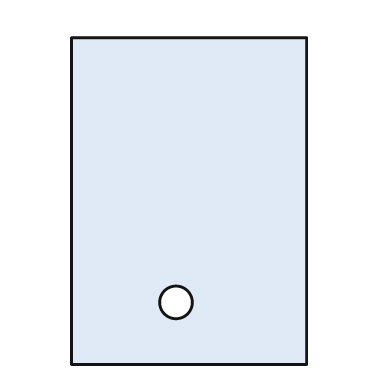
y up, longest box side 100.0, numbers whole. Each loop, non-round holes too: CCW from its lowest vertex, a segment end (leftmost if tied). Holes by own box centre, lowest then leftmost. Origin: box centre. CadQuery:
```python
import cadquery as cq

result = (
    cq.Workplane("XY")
    .moveTo(-36.0, -50.0)
    .lineTo(36.0, -50.0)
    .lineTo(36.0, 50.0)
    .lineTo(-36.0, 50.0)
    .close()
    .moveTo(-4.0, -31.0)
    .circle(5.0)
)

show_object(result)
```